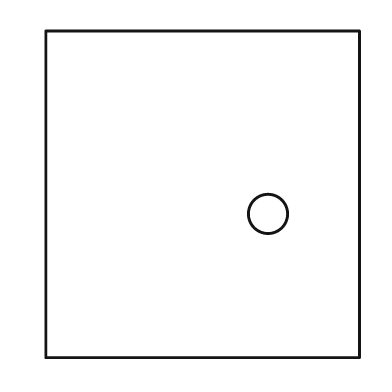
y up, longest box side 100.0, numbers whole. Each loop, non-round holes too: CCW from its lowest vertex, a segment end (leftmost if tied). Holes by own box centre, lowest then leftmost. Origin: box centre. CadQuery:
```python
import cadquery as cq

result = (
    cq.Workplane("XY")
    .moveTo(-48.0, -50.0)
    .lineTo(48.0, -50.0)
    .lineTo(48.0, 50.0)
    .lineTo(-48.0, 50.0)
    .close()
    .moveTo(20.0, -6.0)
    .circle(6.0)
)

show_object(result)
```